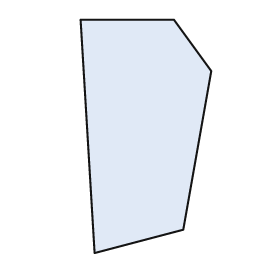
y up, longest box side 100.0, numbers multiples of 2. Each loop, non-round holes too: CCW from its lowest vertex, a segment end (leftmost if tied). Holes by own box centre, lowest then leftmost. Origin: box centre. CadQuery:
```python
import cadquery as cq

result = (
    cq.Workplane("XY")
    .moveTo(-22.0, -50.0)
    .lineTo(16.0, -40.0)
    .lineTo(28.0, 28.0)
    .lineTo(12.0, 50.0)
    .lineTo(-28.0, 50.0)
    .close()
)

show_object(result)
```